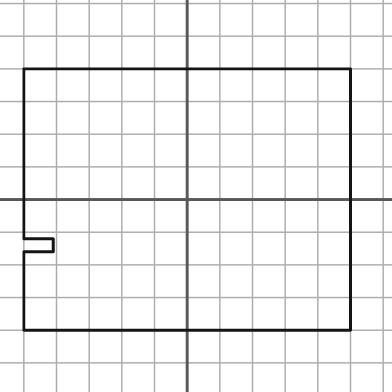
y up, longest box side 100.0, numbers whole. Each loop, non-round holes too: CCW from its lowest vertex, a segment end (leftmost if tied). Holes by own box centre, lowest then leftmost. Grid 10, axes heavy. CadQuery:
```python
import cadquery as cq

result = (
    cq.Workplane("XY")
    .moveTo(-50.0, -40.0)
    .lineTo(50.0, -40.0)
    .lineTo(50.0, 40.0)
    .lineTo(-50.0, 40.0)
    .lineTo(-50.0, -12.0)
    .lineTo(-41.0, -12.0)
    .lineTo(-41.0, -16.0)
    .lineTo(-50.0, -16.0)
    .close()
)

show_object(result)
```